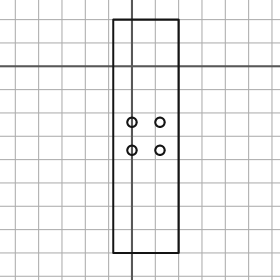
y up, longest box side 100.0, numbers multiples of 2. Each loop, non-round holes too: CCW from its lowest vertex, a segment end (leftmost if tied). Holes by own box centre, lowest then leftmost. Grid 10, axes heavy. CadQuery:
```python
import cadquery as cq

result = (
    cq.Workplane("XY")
    .moveTo(-8.0, -80.0)
    .lineTo(20.0, -80.0)
    .lineTo(20.0, 20.0)
    .lineTo(-8.0, 20.0)
    .close()
    .moveTo(0.0, -36.0)
    .circle(2.0)
    .moveTo(12.0, -36.0)
    .circle(2.0)
    .moveTo(0.0, -24.0)
    .circle(2.0)
    .moveTo(12.0, -24.0)
    .circle(2.0)
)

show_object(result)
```